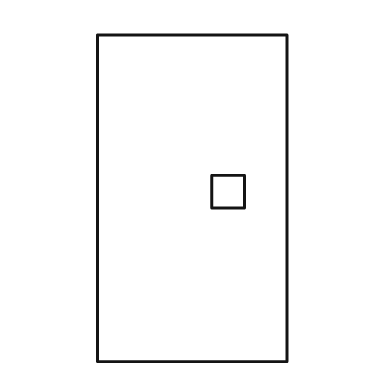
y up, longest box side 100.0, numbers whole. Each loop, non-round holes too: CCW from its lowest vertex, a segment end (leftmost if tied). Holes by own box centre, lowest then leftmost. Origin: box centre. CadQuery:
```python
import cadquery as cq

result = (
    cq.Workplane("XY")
    .moveTo(-29.0, -50.0)
    .lineTo(29.0, -50.0)
    .lineTo(29.0, 50.0)
    .lineTo(-29.0, 50.0)
    .close()
    .moveTo(6.0, -3.0)
    .lineTo(16.0, -3.0)
    .lineTo(16.0, 7.0)
    .lineTo(6.0, 7.0)
    .close()
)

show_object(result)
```